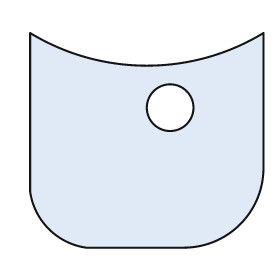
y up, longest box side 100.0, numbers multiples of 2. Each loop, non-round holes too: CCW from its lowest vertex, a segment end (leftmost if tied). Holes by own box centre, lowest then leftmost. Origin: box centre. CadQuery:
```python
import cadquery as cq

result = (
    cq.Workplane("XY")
    .moveTo(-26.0, -46.0)
    .lineTo(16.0, -46.0)
    .threePointArc((40.0, -36.0), (50.0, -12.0))
    .lineTo(50.0, 46.0)
    .threePointArc((0.0, 32.0), (-50.0, 46.0))
    .lineTo(-50.0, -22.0)
    .threePointArc((-42.0, -38.0), (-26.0, -46.0))
    .close()
    .moveTo(10.0, 14.0)
    .circle(10.0)
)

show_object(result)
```